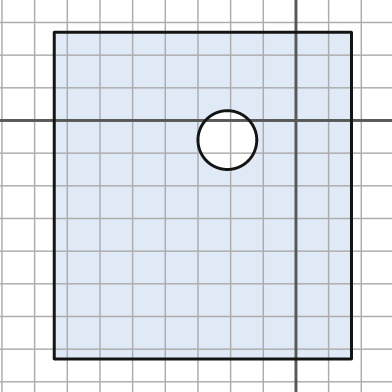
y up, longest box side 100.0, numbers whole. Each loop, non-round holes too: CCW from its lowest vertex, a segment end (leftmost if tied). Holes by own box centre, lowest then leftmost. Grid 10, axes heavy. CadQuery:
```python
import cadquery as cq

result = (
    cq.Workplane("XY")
    .moveTo(-74.0, -73.0)
    .lineTo(17.0, -73.0)
    .lineTo(17.0, 27.0)
    .lineTo(-74.0, 27.0)
    .close()
    .moveTo(-21.0, -6.0)
    .circle(9.0)
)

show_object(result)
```